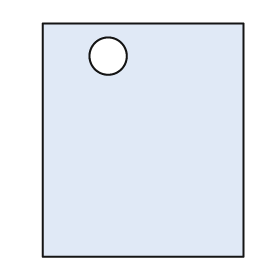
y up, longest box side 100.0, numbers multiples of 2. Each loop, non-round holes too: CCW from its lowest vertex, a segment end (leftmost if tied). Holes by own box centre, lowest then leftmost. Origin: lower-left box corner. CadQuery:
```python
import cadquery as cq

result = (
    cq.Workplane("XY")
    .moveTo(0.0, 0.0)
    .lineTo(86.0, 0.0)
    .lineTo(86.0, 100.0)
    .lineTo(0.0, 100.0)
    .close()
    .moveTo(28.0, 86.0)
    .circle(8.0)
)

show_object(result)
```